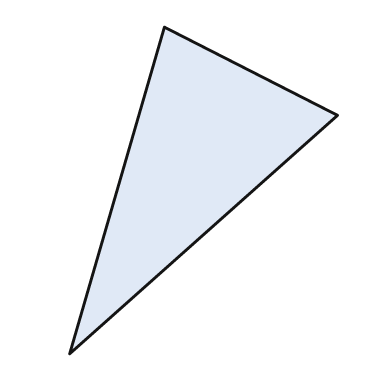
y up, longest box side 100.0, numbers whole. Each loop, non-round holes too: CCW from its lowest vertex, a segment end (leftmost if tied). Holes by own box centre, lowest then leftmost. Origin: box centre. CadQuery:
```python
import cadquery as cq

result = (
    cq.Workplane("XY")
    .moveTo(-41.0, -50.0)
    .lineTo(41.0, 23.0)
    .lineTo(-12.0, 50.0)
    .close()
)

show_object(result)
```